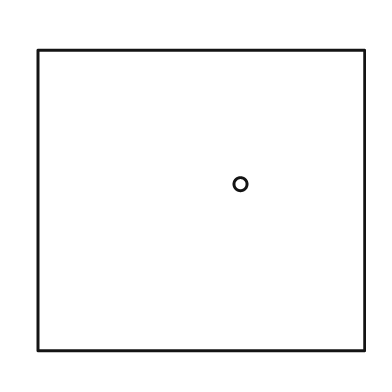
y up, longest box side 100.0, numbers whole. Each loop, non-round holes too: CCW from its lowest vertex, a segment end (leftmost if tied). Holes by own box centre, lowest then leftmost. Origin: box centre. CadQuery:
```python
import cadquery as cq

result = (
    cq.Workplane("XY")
    .moveTo(-50.0, -46.0)
    .lineTo(50.0, -46.0)
    .lineTo(50.0, 46.0)
    .lineTo(-50.0, 46.0)
    .close()
    .moveTo(12.0, 5.0)
    .circle(2.0)
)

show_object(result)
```